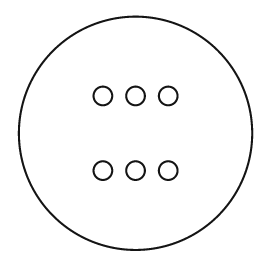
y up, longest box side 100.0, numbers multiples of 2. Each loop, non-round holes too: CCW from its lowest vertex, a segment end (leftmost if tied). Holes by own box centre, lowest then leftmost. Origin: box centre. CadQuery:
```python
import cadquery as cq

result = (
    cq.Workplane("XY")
    .moveTo(0.0, 0.0)
    .circle(50.0)
    .moveTo(-14.0, -16.0)
    .circle(4.0)
    .moveTo(0.0, -16.0)
    .circle(4.0)
    .moveTo(14.0, -16.0)
    .circle(4.0)
    .moveTo(-14.0, 16.0)
    .circle(4.0)
    .moveTo(0.0, 16.0)
    .circle(4.0)
    .moveTo(14.0, 16.0)
    .circle(4.0)
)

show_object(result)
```